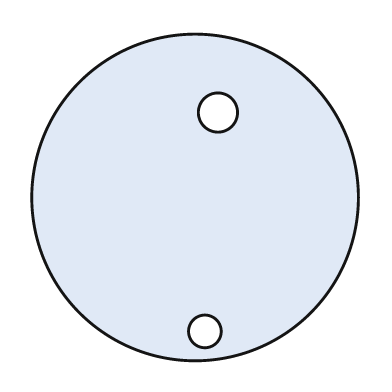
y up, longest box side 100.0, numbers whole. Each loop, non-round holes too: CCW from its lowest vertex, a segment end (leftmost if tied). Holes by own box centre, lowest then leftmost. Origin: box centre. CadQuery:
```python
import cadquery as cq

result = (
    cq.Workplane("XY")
    .moveTo(0.0, 0.0)
    .circle(50.0)
    .moveTo(3.0, -41.0)
    .circle(5.0)
    .moveTo(7.0, 26.0)
    .circle(6.0)
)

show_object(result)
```